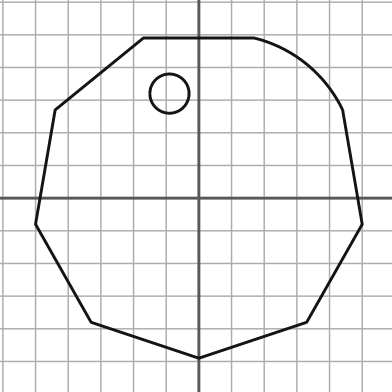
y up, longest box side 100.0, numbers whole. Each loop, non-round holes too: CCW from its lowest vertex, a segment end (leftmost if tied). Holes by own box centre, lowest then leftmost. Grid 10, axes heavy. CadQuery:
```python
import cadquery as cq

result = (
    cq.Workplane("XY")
    .moveTo(0.0, -49.0)
    .lineTo(33.0, -38.0)
    .lineTo(50.0, -8.0)
    .lineTo(44.0, 27.0)
    .threePointArc((33.0, 41.0), (17.0, 49.0))
    .lineTo(-17.0, 49.0)
    .lineTo(-44.0, 27.0)
    .lineTo(-50.0, -8.0)
    .lineTo(-33.0, -38.0)
    .close()
    .moveTo(-9.0, 32.0)
    .circle(6.0)
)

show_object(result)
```